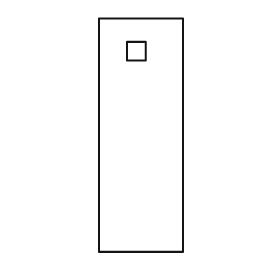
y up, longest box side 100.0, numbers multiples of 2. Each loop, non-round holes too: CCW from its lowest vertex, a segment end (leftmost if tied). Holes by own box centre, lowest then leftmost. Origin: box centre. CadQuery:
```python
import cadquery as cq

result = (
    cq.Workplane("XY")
    .moveTo(-18.0, -50.0)
    .lineTo(18.0, -50.0)
    .lineTo(18.0, 50.0)
    .lineTo(-18.0, 50.0)
    .close()
    .moveTo(-6.0, 32.0)
    .lineTo(2.0, 32.0)
    .lineTo(2.0, 40.0)
    .lineTo(-6.0, 40.0)
    .close()
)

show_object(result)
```